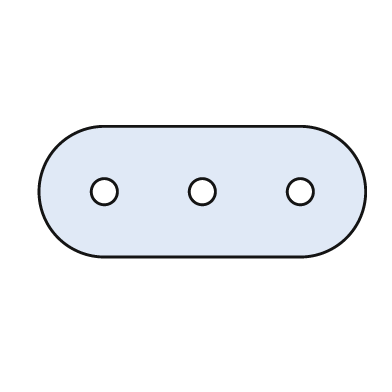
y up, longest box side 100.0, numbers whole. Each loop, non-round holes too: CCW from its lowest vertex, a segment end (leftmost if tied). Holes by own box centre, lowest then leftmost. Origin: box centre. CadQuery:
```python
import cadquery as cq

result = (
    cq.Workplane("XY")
    .moveTo(-30.0, -20.0)
    .lineTo(30.0, -20.0)
    .threePointArc((50.0, 0.0), (30.0, 20.0))
    .lineTo(-30.0, 20.0)
    .threePointArc((-50.0, 0.0), (-30.0, -20.0))
    .close()
    .moveTo(-30.0, 0.0)
    .circle(4.0)
    .moveTo(0.0, 0.0)
    .circle(4.0)
    .moveTo(30.0, 0.0)
    .circle(4.0)
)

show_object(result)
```